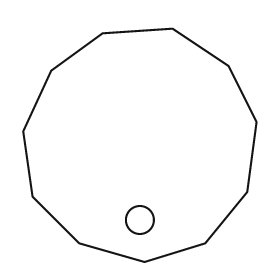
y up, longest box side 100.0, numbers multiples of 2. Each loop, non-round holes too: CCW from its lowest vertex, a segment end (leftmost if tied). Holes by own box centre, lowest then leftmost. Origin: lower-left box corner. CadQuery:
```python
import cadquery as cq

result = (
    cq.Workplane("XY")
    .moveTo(52.0, 0.0)
    .lineTo(78.0, 8.0)
    .lineTo(96.0, 30.0)
    .lineTo(100.0, 60.0)
    .lineTo(88.0, 84.0)
    .lineTo(64.0, 100.0)
    .lineTo(34.0, 98.0)
    .lineTo(12.0, 82.0)
    .lineTo(0.0, 56.0)
    .lineTo(4.0, 28.0)
    .lineTo(24.0, 8.0)
    .close()
    .moveTo(50.0, 18.0)
    .circle(6.0)
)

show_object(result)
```